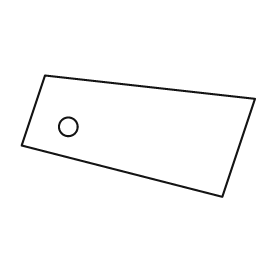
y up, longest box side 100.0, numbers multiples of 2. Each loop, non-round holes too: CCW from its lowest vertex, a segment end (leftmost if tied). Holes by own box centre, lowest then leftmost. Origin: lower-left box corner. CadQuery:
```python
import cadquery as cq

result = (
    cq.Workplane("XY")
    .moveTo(86.0, 0.0)
    .lineTo(100.0, 42.0)
    .lineTo(10.0, 52.0)
    .lineTo(0.0, 22.0)
    .close()
    .moveTo(20.0, 30.0)
    .circle(4.0)
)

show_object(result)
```